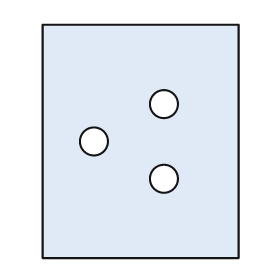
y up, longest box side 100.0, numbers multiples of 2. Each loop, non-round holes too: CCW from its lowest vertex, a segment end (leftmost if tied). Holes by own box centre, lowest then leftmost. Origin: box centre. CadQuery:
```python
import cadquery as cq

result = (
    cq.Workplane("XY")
    .moveTo(-42.0, -50.0)
    .lineTo(42.0, -50.0)
    .lineTo(42.0, 50.0)
    .lineTo(-42.0, 50.0)
    .close()
    .moveTo(10.0, -16.0)
    .circle(6.0)
    .moveTo(-20.0, 0.0)
    .circle(6.0)
    .moveTo(10.0, 16.0)
    .circle(6.0)
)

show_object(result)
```